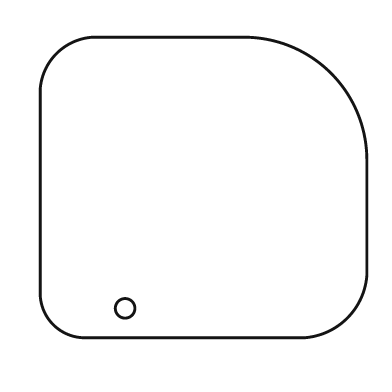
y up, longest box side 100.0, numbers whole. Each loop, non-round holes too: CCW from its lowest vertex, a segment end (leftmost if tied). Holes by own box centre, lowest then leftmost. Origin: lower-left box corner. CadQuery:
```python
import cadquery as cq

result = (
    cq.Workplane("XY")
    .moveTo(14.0, 0.0)
    .lineTo(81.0, 0.0)
    .threePointArc((94.0, 6.0), (100.0, 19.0))
    .lineTo(100.0, 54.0)
    .threePointArc((89.0, 81.0), (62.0, 92.0))
    .lineTo(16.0, 92.0)
    .threePointArc((5.0, 87.0), (0.0, 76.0))
    .lineTo(0.0, 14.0)
    .threePointArc((4.0, 4.0), (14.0, 0.0))
    .close()
    .moveTo(26.0, 9.0)
    .circle(3.0)
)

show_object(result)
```